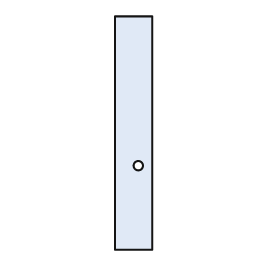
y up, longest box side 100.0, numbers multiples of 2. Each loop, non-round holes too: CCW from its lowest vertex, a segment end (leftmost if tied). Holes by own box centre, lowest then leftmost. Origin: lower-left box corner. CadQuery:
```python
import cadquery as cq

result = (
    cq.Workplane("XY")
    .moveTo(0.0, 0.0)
    .lineTo(16.0, 0.0)
    .lineTo(16.0, 100.0)
    .lineTo(0.0, 100.0)
    .close()
    .moveTo(10.0, 36.0)
    .circle(2.0)
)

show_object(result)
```